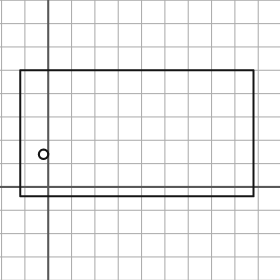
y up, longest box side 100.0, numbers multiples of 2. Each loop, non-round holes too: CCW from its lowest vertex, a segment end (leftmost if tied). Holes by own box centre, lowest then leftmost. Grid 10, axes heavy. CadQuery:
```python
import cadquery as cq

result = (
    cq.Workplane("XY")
    .moveTo(-12.0, -4.0)
    .lineTo(88.0, -4.0)
    .lineTo(88.0, 50.0)
    .lineTo(-12.0, 50.0)
    .close()
    .moveTo(-2.0, 14.0)
    .circle(2.0)
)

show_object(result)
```